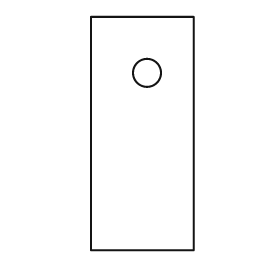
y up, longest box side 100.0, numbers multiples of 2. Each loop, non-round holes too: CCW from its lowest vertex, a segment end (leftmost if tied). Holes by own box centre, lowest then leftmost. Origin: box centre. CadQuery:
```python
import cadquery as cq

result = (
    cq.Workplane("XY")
    .moveTo(-22.0, -50.0)
    .lineTo(22.0, -50.0)
    .lineTo(22.0, 50.0)
    .lineTo(-22.0, 50.0)
    .close()
    .moveTo(2.0, 26.0)
    .circle(6.0)
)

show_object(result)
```